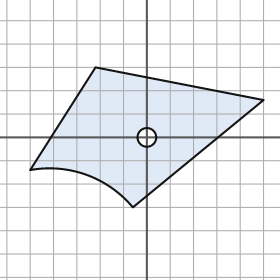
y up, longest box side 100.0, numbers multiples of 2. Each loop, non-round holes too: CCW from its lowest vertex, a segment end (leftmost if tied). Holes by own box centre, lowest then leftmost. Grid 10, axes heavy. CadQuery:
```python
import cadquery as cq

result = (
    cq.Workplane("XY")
    .moveTo(-6.0, -30.0)
    .lineTo(50.0, 16.0)
    .lineTo(-22.0, 30.0)
    .lineTo(-50.0, -14.0)
    .threePointArc((-26.0, -16.0), (-6.0, -30.0))
    .close()
    .moveTo(0.0, 0.0)
    .circle(4.0)
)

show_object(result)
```